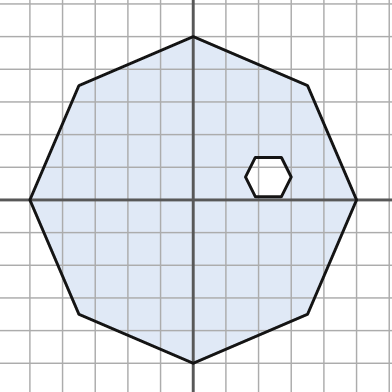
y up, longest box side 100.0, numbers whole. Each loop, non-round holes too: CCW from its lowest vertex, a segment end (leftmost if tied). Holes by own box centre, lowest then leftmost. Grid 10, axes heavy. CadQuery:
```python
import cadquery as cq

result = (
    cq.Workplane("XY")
    .moveTo(0.0, -50.0)
    .lineTo(35.0, -35.0)
    .lineTo(50.0, 0.0)
    .lineTo(35.0, 35.0)
    .lineTo(0.0, 50.0)
    .lineTo(-35.0, 35.0)
    .lineTo(-50.0, 0.0)
    .lineTo(-35.0, -35.0)
    .close()
    .moveTo(19.0, 1.0)
    .lineTo(27.0, 1.0)
    .lineTo(30.0, 7.0)
    .lineTo(27.0, 13.0)
    .lineTo(19.0, 13.0)
    .lineTo(16.0, 7.0)
    .close()
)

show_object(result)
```